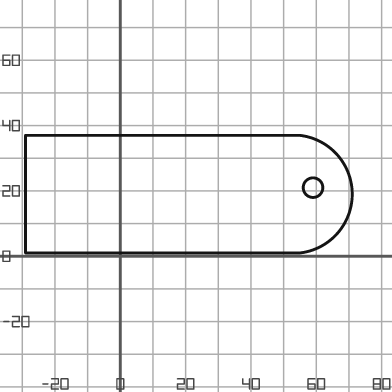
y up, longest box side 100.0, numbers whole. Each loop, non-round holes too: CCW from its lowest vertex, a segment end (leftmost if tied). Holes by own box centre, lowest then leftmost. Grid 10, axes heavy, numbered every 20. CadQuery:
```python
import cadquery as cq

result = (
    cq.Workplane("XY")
    .moveTo(-29.0, 1.0)
    .lineTo(55.0, 1.0)
    .threePointArc((71.0, 19.0), (55.0, 37.0))
    .lineTo(-29.0, 37.0)
    .close()
    .moveTo(59.0, 21.0)
    .circle(3.0)
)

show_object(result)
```